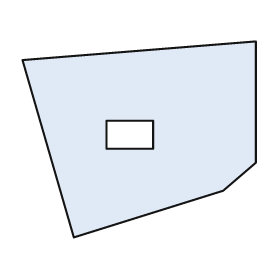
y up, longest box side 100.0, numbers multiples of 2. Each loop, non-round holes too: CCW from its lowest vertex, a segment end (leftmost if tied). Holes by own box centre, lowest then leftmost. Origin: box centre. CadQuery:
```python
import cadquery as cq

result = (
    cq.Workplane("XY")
    .moveTo(-28.0, -42.0)
    .lineTo(36.0, -22.0)
    .lineTo(50.0, -10.0)
    .lineTo(50.0, 42.0)
    .lineTo(-50.0, 34.0)
    .close()
    .moveTo(-14.0, -4.0)
    .lineTo(6.0, -4.0)
    .lineTo(6.0, 8.0)
    .lineTo(-14.0, 8.0)
    .close()
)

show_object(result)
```